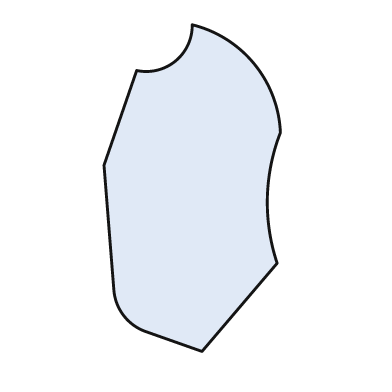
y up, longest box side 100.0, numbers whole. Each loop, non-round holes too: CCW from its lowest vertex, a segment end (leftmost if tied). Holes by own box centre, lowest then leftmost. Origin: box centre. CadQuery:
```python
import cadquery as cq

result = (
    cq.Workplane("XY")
    .moveTo(3.0, -50.0)
    .lineTo(26.0, -23.0)
    .threePointArc((23.0, -3.0), (27.0, 17.0))
    .threePointArc((19.0, 38.0), (0.0, 50.0))
    .threePointArc((-5.0, 39.0), (-17.0, 36.0))
    .lineTo(-27.0, 7.0)
    .lineTo(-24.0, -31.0)
    .threePointArc((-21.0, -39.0), (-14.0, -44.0))
    .close()
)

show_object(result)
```